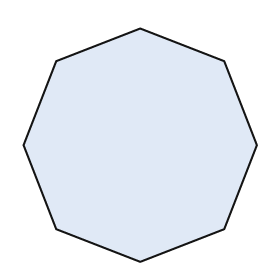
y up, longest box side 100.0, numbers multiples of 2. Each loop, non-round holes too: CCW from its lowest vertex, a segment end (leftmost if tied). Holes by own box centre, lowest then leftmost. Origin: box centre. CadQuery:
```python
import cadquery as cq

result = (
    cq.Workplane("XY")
    .moveTo(0.0, -50.0)
    .lineTo(36.0, -36.0)
    .lineTo(50.0, 0.0)
    .lineTo(36.0, 36.0)
    .lineTo(0.0, 50.0)
    .lineTo(-36.0, 36.0)
    .lineTo(-50.0, 0.0)
    .lineTo(-36.0, -36.0)
    .close()
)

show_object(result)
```